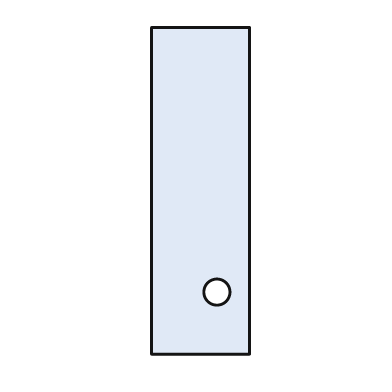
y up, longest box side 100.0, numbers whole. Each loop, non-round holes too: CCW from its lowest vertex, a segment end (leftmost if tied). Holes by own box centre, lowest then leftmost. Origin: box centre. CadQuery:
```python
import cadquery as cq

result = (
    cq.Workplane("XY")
    .moveTo(-15.0, -50.0)
    .lineTo(15.0, -50.0)
    .lineTo(15.0, 50.0)
    .lineTo(-15.0, 50.0)
    .close()
    .moveTo(5.0, -31.0)
    .circle(4.0)
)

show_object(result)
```